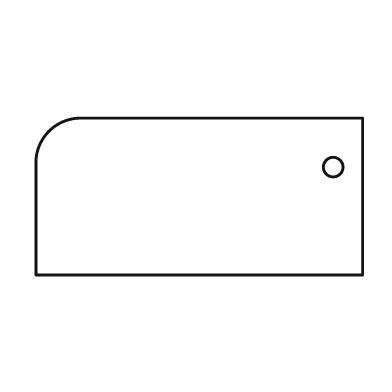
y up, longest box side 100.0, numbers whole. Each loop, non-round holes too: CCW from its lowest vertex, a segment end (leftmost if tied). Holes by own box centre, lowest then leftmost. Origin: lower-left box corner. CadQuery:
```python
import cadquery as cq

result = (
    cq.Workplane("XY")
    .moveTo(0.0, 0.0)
    .lineTo(100.0, 0.0)
    .lineTo(100.0, 48.0)
    .lineTo(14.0, 48.0)
    .threePointArc((4.0, 44.0), (0.0, 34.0))
    .close()
    .moveTo(91.0, 33.0)
    .circle(3.0)
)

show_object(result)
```